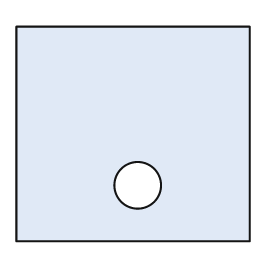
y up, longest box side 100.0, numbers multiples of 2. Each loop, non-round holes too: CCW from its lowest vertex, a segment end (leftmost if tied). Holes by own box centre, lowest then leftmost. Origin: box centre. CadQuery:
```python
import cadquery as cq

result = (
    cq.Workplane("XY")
    .moveTo(-50.0, -46.0)
    .lineTo(50.0, -46.0)
    .lineTo(50.0, 46.0)
    .lineTo(-50.0, 46.0)
    .close()
    .moveTo(2.0, -22.0)
    .circle(10.0)
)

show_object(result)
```